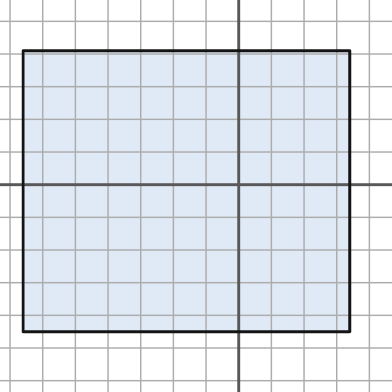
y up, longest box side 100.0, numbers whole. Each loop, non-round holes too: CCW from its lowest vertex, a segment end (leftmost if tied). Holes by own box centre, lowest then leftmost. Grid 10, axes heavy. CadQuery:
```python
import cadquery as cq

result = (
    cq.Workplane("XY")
    .moveTo(-66.0, -45.0)
    .lineTo(34.0, -45.0)
    .lineTo(34.0, 41.0)
    .lineTo(-66.0, 41.0)
    .close()
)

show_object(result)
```